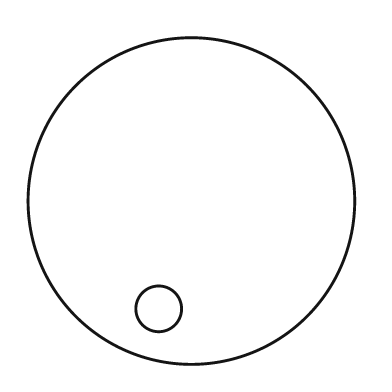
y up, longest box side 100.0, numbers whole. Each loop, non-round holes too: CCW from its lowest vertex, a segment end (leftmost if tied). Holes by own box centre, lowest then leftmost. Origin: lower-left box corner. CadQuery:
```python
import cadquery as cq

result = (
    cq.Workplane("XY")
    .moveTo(50.0, 50.0)
    .circle(50.0)
    .moveTo(40.0, 17.0)
    .circle(7.0)
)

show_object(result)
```